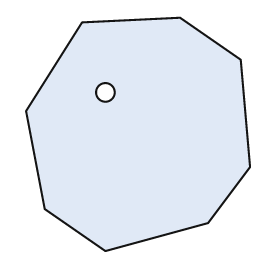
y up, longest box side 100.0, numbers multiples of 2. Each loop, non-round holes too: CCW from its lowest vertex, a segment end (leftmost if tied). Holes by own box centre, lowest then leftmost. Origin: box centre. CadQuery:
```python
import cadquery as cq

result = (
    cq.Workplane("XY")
    .moveTo(-14.0, -50.0)
    .lineTo(30.0, -38.0)
    .lineTo(48.0, -14.0)
    .lineTo(44.0, 32.0)
    .lineTo(18.0, 50.0)
    .lineTo(-24.0, 48.0)
    .lineTo(-48.0, 10.0)
    .lineTo(-40.0, -32.0)
    .close()
    .moveTo(-14.0, 18.0)
    .circle(4.0)
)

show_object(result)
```